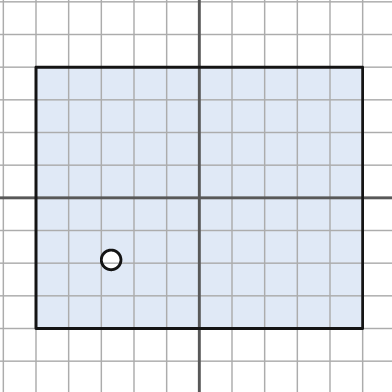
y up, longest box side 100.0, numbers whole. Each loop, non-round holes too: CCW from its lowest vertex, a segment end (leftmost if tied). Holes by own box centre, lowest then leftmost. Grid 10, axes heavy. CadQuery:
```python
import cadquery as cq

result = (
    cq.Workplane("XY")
    .moveTo(-50.0, -40.0)
    .lineTo(50.0, -40.0)
    .lineTo(50.0, 40.0)
    .lineTo(-50.0, 40.0)
    .close()
    .moveTo(-27.0, -19.0)
    .circle(3.0)
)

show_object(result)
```